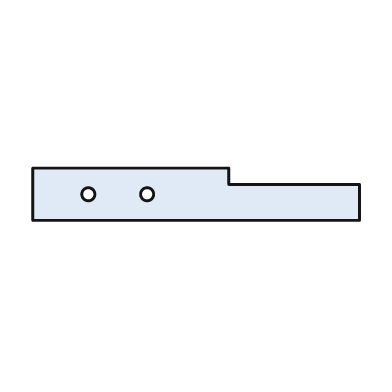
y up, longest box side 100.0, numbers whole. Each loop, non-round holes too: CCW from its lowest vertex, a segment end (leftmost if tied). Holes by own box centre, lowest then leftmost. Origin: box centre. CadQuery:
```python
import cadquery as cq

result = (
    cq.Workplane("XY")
    .moveTo(-50.0, -8.0)
    .lineTo(50.0, -8.0)
    .lineTo(50.0, 3.0)
    .lineTo(10.0, 3.0)
    .lineTo(10.0, 8.0)
    .lineTo(-50.0, 8.0)
    .close()
    .moveTo(-33.0, 0.0)
    .circle(2.0)
    .moveTo(-15.0, 0.0)
    .circle(2.0)
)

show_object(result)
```